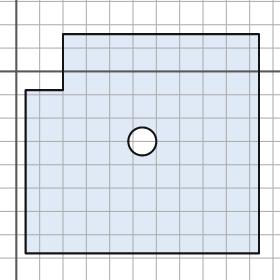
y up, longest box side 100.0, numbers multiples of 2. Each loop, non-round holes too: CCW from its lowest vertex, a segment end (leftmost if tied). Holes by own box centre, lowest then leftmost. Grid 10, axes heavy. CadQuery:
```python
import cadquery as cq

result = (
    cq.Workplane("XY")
    .moveTo(4.0, -78.0)
    .lineTo(104.0, -78.0)
    .lineTo(104.0, 16.0)
    .lineTo(20.0, 16.0)
    .lineTo(20.0, -8.0)
    .lineTo(4.0, -8.0)
    .close()
    .moveTo(54.0, -30.0)
    .circle(6.0)
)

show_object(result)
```